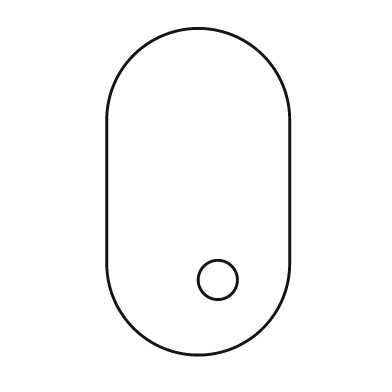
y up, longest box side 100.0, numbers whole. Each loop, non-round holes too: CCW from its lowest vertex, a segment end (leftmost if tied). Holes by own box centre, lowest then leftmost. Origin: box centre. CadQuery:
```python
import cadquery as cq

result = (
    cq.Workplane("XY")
    .moveTo(-28.0, -22.0)
    .threePointArc((0.0, -50.0), (28.0, -22.0))
    .lineTo(28.0, 22.0)
    .threePointArc((0.0, 50.0), (-28.0, 22.0))
    .close()
    .moveTo(6.0, -27.0)
    .circle(6.0)
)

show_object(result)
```